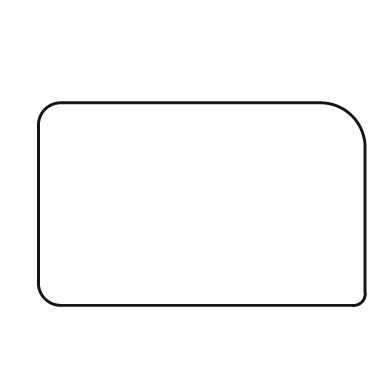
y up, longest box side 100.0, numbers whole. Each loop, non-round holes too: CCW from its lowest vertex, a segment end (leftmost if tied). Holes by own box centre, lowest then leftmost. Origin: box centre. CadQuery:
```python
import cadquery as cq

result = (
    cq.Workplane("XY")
    .moveTo(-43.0, -31.0)
    .lineTo(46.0, -31.0)
    .threePointArc((49.0, -30.0), (50.0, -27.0))
    .lineTo(50.0, 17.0)
    .threePointArc((46.0, 27.0), (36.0, 31.0))
    .lineTo(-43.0, 31.0)
    .threePointArc((-48.0, 29.0), (-50.0, 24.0))
    .lineTo(-50.0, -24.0)
    .threePointArc((-48.0, -29.0), (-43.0, -31.0))
    .close()
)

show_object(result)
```